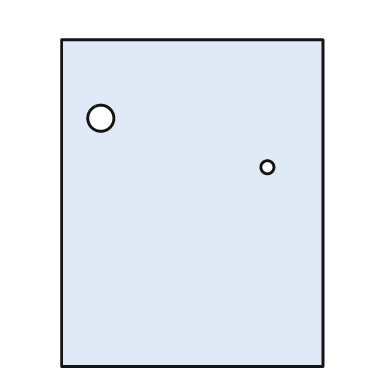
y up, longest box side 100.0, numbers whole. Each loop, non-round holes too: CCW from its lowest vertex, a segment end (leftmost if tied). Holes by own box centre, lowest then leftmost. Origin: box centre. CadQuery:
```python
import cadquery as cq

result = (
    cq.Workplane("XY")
    .moveTo(-40.0, -50.0)
    .lineTo(40.0, -50.0)
    .lineTo(40.0, 50.0)
    .lineTo(-40.0, 50.0)
    .close()
    .moveTo(23.0, 11.0)
    .circle(2.0)
    .moveTo(-28.0, 26.0)
    .circle(4.0)
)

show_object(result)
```